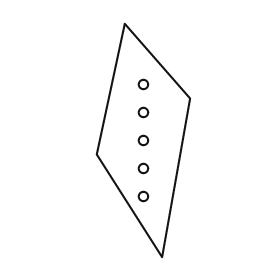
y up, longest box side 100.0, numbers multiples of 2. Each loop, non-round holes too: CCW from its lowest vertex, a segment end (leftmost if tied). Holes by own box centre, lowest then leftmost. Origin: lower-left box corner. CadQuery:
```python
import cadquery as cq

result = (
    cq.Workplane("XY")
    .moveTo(28.0, 0.0)
    .lineTo(40.0, 68.0)
    .lineTo(12.0, 100.0)
    .lineTo(0.0, 44.0)
    .close()
    .moveTo(20.0, 26.0)
    .circle(2.0)
    .moveTo(20.0, 38.0)
    .circle(2.0)
    .moveTo(20.0, 50.0)
    .circle(2.0)
    .moveTo(20.0, 62.0)
    .circle(2.0)
    .moveTo(20.0, 74.0)
    .circle(2.0)
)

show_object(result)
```